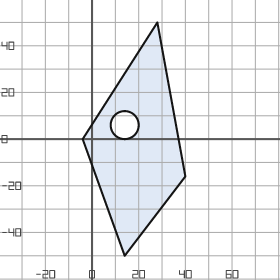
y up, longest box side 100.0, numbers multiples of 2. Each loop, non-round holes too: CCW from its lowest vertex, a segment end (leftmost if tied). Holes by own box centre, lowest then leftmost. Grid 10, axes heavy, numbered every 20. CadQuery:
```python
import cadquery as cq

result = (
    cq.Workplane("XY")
    .moveTo(14.0, -50.0)
    .lineTo(40.0, -16.0)
    .lineTo(28.0, 50.0)
    .lineTo(-4.0, 0.0)
    .close()
    .moveTo(14.0, 6.0)
    .circle(6.0)
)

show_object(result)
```